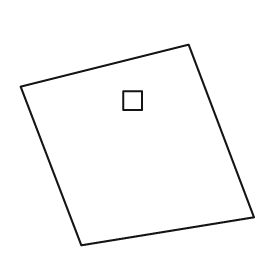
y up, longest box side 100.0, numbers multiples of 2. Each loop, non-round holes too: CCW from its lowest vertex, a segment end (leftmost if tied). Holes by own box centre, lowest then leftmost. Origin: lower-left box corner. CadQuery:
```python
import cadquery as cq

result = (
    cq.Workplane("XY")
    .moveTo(26.0, 0.0)
    .lineTo(100.0, 12.0)
    .lineTo(72.0, 86.0)
    .lineTo(0.0, 68.0)
    .close()
    .moveTo(44.0, 58.0)
    .lineTo(52.0, 58.0)
    .lineTo(52.0, 66.0)
    .lineTo(44.0, 66.0)
    .close()
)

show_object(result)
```